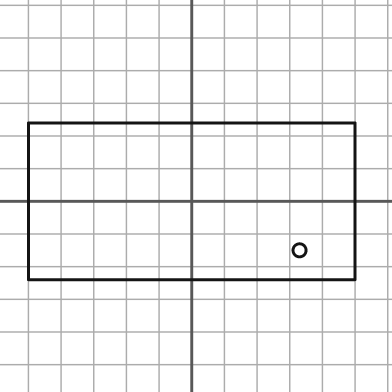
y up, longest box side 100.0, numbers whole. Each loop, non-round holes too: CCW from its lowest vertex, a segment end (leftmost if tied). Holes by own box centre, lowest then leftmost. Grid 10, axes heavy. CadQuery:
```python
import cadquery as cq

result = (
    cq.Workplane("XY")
    .moveTo(-50.0, -24.0)
    .lineTo(50.0, -24.0)
    .lineTo(50.0, 24.0)
    .lineTo(-50.0, 24.0)
    .close()
    .moveTo(33.0, -15.0)
    .circle(2.0)
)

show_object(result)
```